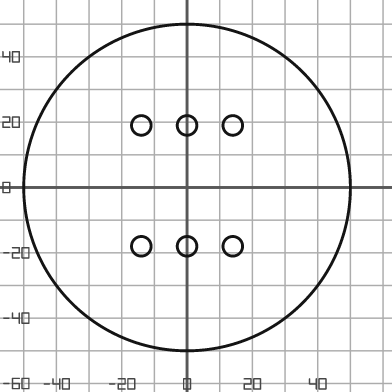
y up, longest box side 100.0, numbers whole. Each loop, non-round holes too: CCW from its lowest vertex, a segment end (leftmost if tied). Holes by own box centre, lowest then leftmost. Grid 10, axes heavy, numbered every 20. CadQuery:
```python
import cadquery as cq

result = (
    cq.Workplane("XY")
    .moveTo(0.0, 0.0)
    .circle(50.0)
    .moveTo(-14.0, -18.0)
    .circle(3.0)
    .moveTo(0.0, -18.0)
    .circle(3.0)
    .moveTo(14.0, -18.0)
    .circle(3.0)
    .moveTo(-14.0, 19.0)
    .circle(3.0)
    .moveTo(0.0, 19.0)
    .circle(3.0)
    .moveTo(14.0, 19.0)
    .circle(3.0)
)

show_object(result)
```